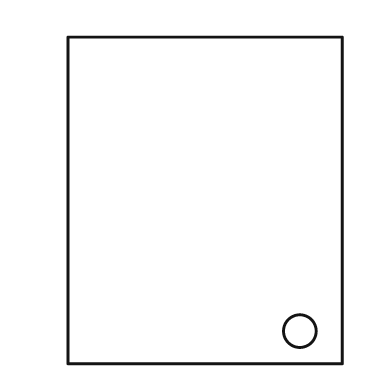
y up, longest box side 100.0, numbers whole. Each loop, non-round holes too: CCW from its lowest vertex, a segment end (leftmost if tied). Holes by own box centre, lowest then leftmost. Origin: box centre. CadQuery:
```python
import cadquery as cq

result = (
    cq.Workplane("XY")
    .moveTo(-42.0, -50.0)
    .lineTo(42.0, -50.0)
    .lineTo(42.0, 50.0)
    .lineTo(-42.0, 50.0)
    .close()
    .moveTo(29.0, -40.0)
    .circle(5.0)
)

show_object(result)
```